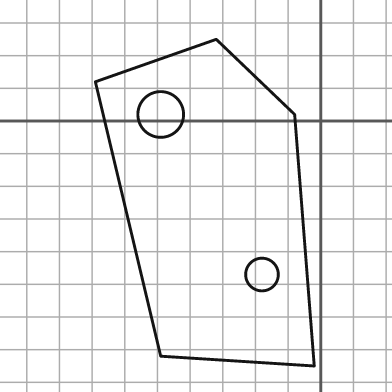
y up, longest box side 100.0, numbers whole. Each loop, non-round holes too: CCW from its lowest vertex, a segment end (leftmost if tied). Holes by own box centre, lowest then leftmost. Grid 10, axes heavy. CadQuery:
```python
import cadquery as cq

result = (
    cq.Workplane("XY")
    .moveTo(-2.0, -75.0)
    .lineTo(-8.0, 2.0)
    .lineTo(-32.0, 25.0)
    .lineTo(-69.0, 12.0)
    .lineTo(-49.0, -72.0)
    .close()
    .moveTo(-18.0, -47.0)
    .circle(5.0)
    .moveTo(-49.0, 2.0)
    .circle(7.0)
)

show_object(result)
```